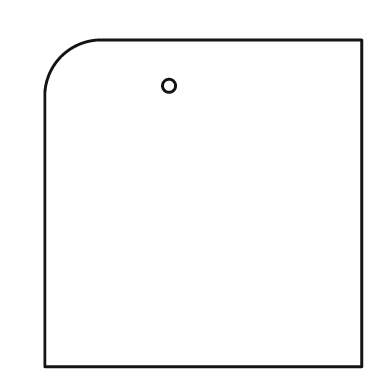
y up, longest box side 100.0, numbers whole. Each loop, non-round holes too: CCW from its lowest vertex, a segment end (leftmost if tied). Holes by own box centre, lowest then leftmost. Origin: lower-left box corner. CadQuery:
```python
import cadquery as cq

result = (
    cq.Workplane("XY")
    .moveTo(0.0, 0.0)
    .lineTo(97.0, 0.0)
    .lineTo(97.0, 100.0)
    .lineTo(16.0, 100.0)
    .threePointArc((5.0, 95.0), (0.0, 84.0))
    .close()
    .moveTo(38.0, 86.0)
    .circle(2.0)
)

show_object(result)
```